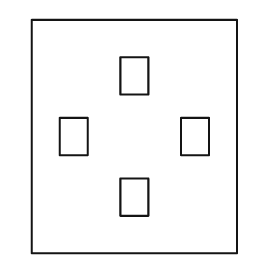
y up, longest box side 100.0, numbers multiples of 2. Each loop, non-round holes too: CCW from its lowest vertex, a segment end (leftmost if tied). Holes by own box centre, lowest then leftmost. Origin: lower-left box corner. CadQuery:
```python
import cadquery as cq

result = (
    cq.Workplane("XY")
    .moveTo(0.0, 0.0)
    .lineTo(88.0, 0.0)
    .lineTo(88.0, 100.0)
    .lineTo(0.0, 100.0)
    .close()
    .moveTo(38.0, 16.0)
    .lineTo(50.0, 16.0)
    .lineTo(50.0, 32.0)
    .lineTo(38.0, 32.0)
    .close()
    .moveTo(12.0, 42.0)
    .lineTo(24.0, 42.0)
    .lineTo(24.0, 58.0)
    .lineTo(12.0, 58.0)
    .close()
    .moveTo(64.0, 42.0)
    .lineTo(76.0, 42.0)
    .lineTo(76.0, 58.0)
    .lineTo(64.0, 58.0)
    .close()
    .moveTo(38.0, 68.0)
    .lineTo(50.0, 68.0)
    .lineTo(50.0, 84.0)
    .lineTo(38.0, 84.0)
    .close()
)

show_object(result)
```